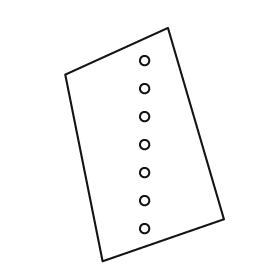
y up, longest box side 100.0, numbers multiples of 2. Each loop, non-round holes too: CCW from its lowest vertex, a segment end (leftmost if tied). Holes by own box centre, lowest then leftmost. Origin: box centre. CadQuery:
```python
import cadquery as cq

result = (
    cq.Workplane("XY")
    .moveTo(-18.0, -50.0)
    .lineTo(34.0, -32.0)
    .lineTo(10.0, 50.0)
    .lineTo(-34.0, 30.0)
    .close()
    .moveTo(0.0, -36.0)
    .circle(2.0)
    .moveTo(0.0, -24.0)
    .circle(2.0)
    .moveTo(0.0, -12.0)
    .circle(2.0)
    .moveTo(0.0, 0.0)
    .circle(2.0)
    .moveTo(0.0, 12.0)
    .circle(2.0)
    .moveTo(0.0, 24.0)
    .circle(2.0)
    .moveTo(0.0, 36.0)
    .circle(2.0)
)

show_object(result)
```